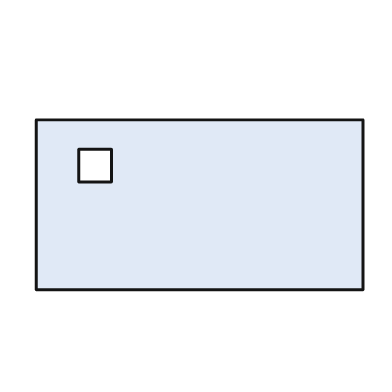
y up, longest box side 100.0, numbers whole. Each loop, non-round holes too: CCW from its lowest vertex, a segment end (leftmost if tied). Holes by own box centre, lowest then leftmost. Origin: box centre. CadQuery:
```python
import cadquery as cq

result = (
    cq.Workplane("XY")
    .moveTo(-50.0, -26.0)
    .lineTo(50.0, -26.0)
    .lineTo(50.0, 26.0)
    .lineTo(-50.0, 26.0)
    .close()
    .moveTo(-37.0, 7.0)
    .lineTo(-27.0, 7.0)
    .lineTo(-27.0, 17.0)
    .lineTo(-37.0, 17.0)
    .close()
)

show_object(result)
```